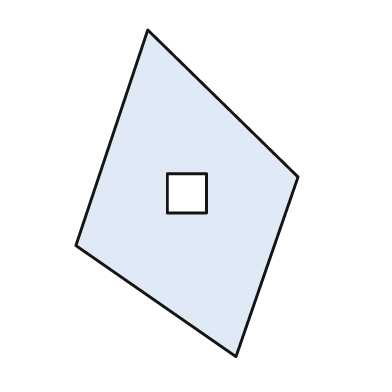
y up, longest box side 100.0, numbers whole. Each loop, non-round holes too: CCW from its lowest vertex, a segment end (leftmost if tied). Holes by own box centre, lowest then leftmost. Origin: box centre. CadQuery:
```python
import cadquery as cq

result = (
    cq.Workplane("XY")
    .moveTo(15.0, -50.0)
    .lineTo(34.0, 5.0)
    .lineTo(-12.0, 50.0)
    .lineTo(-34.0, -16.0)
    .close()
    .moveTo(-6.0, -6.0)
    .lineTo(6.0, -6.0)
    .lineTo(6.0, 6.0)
    .lineTo(-6.0, 6.0)
    .close()
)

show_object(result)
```